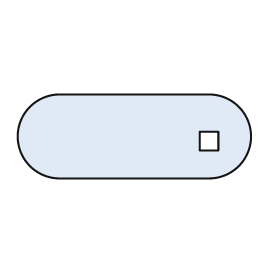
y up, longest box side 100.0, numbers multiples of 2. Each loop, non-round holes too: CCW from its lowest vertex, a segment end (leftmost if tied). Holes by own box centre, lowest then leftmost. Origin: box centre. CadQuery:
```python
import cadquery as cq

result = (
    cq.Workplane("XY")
    .moveTo(-32.0, -18.0)
    .lineTo(32.0, -18.0)
    .threePointArc((50.0, 0.0), (32.0, 18.0))
    .lineTo(-32.0, 18.0)
    .threePointArc((-50.0, 0.0), (-32.0, -18.0))
    .close()
    .moveTo(28.0, -6.0)
    .lineTo(36.0, -6.0)
    .lineTo(36.0, 2.0)
    .lineTo(28.0, 2.0)
    .close()
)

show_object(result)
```